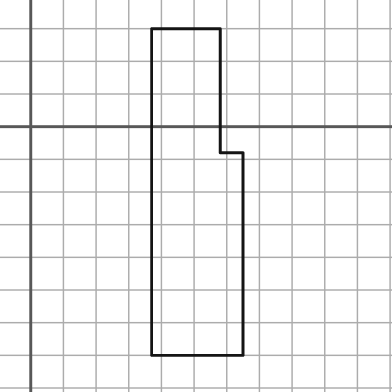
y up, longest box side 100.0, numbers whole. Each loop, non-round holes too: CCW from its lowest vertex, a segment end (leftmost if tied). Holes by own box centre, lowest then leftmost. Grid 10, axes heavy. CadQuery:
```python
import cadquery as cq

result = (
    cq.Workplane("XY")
    .moveTo(37.0, -70.0)
    .lineTo(65.0, -70.0)
    .lineTo(65.0, -8.0)
    .lineTo(58.0, -8.0)
    .lineTo(58.0, 30.0)
    .lineTo(37.0, 30.0)
    .close()
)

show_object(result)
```